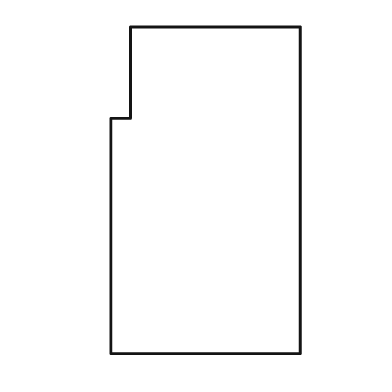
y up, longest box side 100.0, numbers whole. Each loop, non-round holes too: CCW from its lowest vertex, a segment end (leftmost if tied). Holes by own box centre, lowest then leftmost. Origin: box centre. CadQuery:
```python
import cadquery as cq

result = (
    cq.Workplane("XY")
    .moveTo(-29.0, -50.0)
    .lineTo(29.0, -50.0)
    .lineTo(29.0, 50.0)
    .lineTo(-23.0, 50.0)
    .lineTo(-23.0, 22.0)
    .lineTo(-29.0, 22.0)
    .close()
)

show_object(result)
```